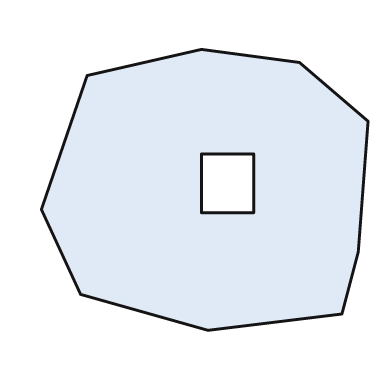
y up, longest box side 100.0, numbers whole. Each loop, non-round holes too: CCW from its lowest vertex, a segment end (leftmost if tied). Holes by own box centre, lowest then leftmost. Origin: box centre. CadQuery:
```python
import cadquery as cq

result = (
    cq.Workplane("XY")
    .moveTo(1.0, -43.0)
    .lineTo(42.0, -38.0)
    .lineTo(47.0, -19.0)
    .lineTo(50.0, 21.0)
    .lineTo(29.0, 39.0)
    .lineTo(-1.0, 43.0)
    .lineTo(-36.0, 35.0)
    .lineTo(-50.0, -6.0)
    .lineTo(-38.0, -32.0)
    .close()
    .moveTo(-1.0, -7.0)
    .lineTo(15.0, -7.0)
    .lineTo(15.0, 11.0)
    .lineTo(-1.0, 11.0)
    .close()
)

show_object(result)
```